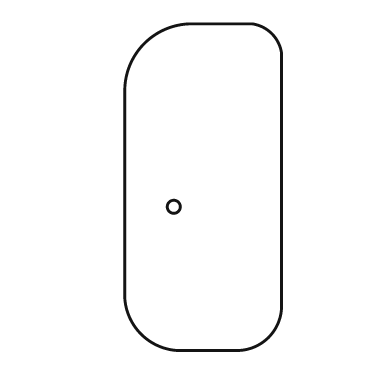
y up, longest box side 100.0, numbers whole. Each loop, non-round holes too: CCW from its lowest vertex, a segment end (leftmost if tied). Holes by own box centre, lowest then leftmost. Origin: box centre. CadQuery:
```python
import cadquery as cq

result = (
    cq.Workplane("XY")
    .moveTo(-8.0, -50.0)
    .lineTo(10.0, -50.0)
    .threePointArc((20.0, -46.0), (24.0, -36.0))
    .lineTo(24.0, 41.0)
    .threePointArc((21.0, 47.0), (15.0, 50.0))
    .lineTo(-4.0, 50.0)
    .threePointArc((-18.0, 44.0), (-24.0, 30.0))
    .lineTo(-24.0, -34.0)
    .threePointArc((-19.0, -45.0), (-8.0, -50.0))
    .close()
    .moveTo(-9.0, -6.0)
    .circle(2.0)
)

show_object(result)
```